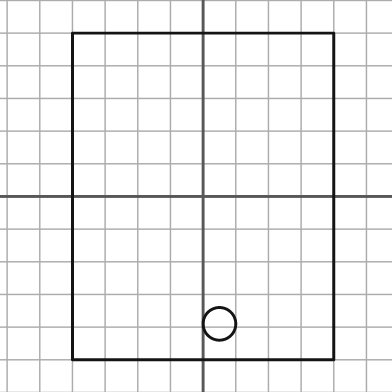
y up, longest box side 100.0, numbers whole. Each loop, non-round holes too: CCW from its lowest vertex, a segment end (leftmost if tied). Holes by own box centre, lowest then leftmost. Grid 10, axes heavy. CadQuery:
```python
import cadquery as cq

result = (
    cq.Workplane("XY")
    .moveTo(-40.0, -50.0)
    .lineTo(40.0, -50.0)
    .lineTo(40.0, 50.0)
    .lineTo(-40.0, 50.0)
    .close()
    .moveTo(5.0, -39.0)
    .circle(5.0)
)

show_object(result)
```